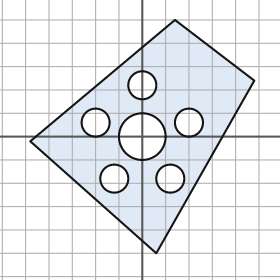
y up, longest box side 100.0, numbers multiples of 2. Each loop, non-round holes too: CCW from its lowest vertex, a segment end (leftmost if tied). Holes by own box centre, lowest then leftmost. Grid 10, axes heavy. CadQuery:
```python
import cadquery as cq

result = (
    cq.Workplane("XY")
    .moveTo(6.0, -50.0)
    .lineTo(48.0, 24.0)
    .lineTo(14.0, 50.0)
    .lineTo(-48.0, -2.0)
    .close()
    .moveTo(-12.0, -18.0)
    .circle(6.0)
    .moveTo(12.0, -18.0)
    .circle(6.0)
    .moveTo(0.0, 0.0)
    .circle(10.0)
    .moveTo(-20.0, 6.0)
    .circle(6.0)
    .moveTo(20.0, 6.0)
    .circle(6.0)
    .moveTo(0.0, 22.0)
    .circle(6.0)
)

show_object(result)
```